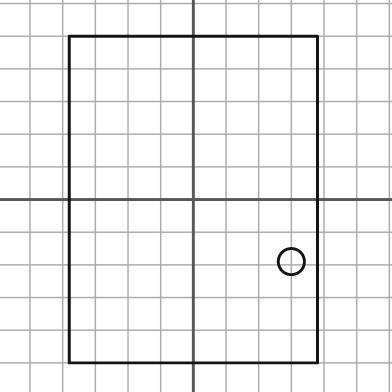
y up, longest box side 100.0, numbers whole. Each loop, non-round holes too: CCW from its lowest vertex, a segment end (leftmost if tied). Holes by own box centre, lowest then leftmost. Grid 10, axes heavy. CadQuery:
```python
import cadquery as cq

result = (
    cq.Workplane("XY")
    .moveTo(-38.0, -50.0)
    .lineTo(38.0, -50.0)
    .lineTo(38.0, 50.0)
    .lineTo(-38.0, 50.0)
    .close()
    .moveTo(30.0, -19.0)
    .circle(4.0)
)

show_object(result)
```